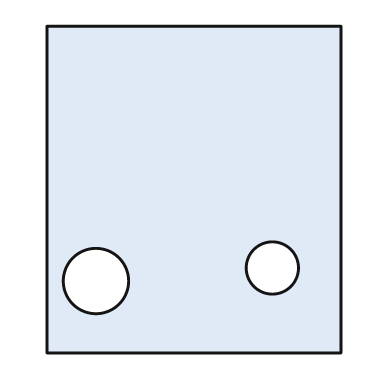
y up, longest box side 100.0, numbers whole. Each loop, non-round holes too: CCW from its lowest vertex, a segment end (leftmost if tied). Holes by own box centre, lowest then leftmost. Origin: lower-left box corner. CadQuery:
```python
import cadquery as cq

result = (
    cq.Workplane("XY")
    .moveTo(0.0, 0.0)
    .lineTo(90.0, 0.0)
    .lineTo(90.0, 100.0)
    .lineTo(0.0, 100.0)
    .close()
    .moveTo(15.0, 22.0)
    .circle(10.0)
    .moveTo(69.0, 26.0)
    .circle(8.0)
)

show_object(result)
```